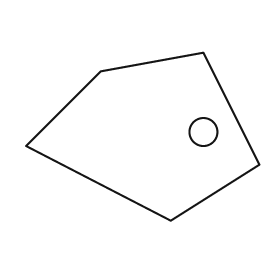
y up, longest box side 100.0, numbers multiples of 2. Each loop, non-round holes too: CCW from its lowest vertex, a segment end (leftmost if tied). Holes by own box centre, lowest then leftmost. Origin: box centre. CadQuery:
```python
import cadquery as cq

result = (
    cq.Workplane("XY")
    .moveTo(12.0, -36.0)
    .lineTo(50.0, -12.0)
    .lineTo(26.0, 36.0)
    .lineTo(-18.0, 28.0)
    .lineTo(-50.0, -4.0)
    .close()
    .moveTo(26.0, 2.0)
    .circle(6.0)
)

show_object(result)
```